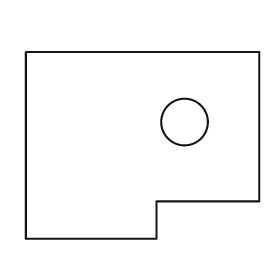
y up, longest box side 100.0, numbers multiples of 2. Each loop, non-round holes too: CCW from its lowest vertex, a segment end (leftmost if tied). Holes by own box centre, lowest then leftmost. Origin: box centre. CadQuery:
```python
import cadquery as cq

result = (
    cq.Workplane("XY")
    .moveTo(-50.0, -40.0)
    .lineTo(6.0, -40.0)
    .lineTo(6.0, -24.0)
    .lineTo(50.0, -24.0)
    .lineTo(50.0, 40.0)
    .lineTo(-50.0, 40.0)
    .close()
    .moveTo(18.0, 10.0)
    .circle(10.0)
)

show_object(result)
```